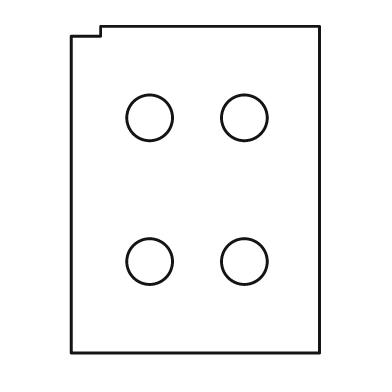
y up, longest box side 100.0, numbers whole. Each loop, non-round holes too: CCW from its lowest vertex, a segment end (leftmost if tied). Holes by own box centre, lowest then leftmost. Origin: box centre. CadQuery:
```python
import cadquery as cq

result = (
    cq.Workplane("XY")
    .moveTo(-38.0, -50.0)
    .lineTo(38.0, -50.0)
    .lineTo(38.0, 50.0)
    .lineTo(-29.0, 50.0)
    .lineTo(-29.0, 47.0)
    .lineTo(-38.0, 47.0)
    .close()
    .moveTo(-14.0, -22.0)
    .circle(7.0)
    .moveTo(15.0, -22.0)
    .circle(7.0)
    .moveTo(-14.0, 22.0)
    .circle(7.0)
    .moveTo(15.0, 22.0)
    .circle(7.0)
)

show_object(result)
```